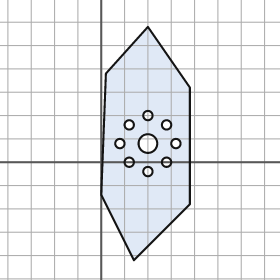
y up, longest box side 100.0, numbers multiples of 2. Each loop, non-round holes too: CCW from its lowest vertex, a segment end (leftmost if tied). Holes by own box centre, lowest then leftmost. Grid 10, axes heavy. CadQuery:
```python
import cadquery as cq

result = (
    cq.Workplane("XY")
    .moveTo(14.0, -42.0)
    .lineTo(38.0, -18.0)
    .lineTo(38.0, 32.0)
    .lineTo(20.0, 58.0)
    .lineTo(2.0, 38.0)
    .lineTo(0.0, -14.0)
    .close()
    .moveTo(20.0, -4.0)
    .circle(2.0)
    .moveTo(12.0, 0.0)
    .circle(2.0)
    .moveTo(28.0, 0.0)
    .circle(2.0)
    .moveTo(8.0, 8.0)
    .circle(2.0)
    .moveTo(20.0, 8.0)
    .circle(4.0)
    .moveTo(32.0, 8.0)
    .circle(2.0)
    .moveTo(12.0, 16.0)
    .circle(2.0)
    .moveTo(28.0, 16.0)
    .circle(2.0)
    .moveTo(20.0, 20.0)
    .circle(2.0)
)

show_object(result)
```